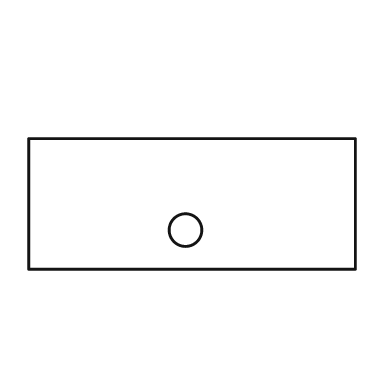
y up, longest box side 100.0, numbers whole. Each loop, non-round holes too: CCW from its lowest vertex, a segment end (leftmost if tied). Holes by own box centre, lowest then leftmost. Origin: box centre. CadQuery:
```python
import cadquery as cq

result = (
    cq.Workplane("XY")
    .moveTo(-50.0, -20.0)
    .lineTo(50.0, -20.0)
    .lineTo(50.0, 20.0)
    .lineTo(-50.0, 20.0)
    .close()
    .moveTo(-2.0, -8.0)
    .circle(5.0)
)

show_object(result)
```